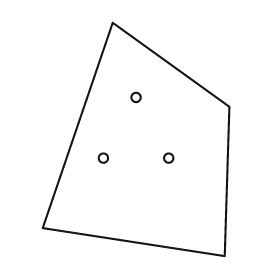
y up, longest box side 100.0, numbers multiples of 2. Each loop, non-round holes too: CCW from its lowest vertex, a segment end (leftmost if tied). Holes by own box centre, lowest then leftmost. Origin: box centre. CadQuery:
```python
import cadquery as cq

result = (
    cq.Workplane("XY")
    .moveTo(38.0, -50.0)
    .lineTo(40.0, 14.0)
    .lineTo(-10.0, 50.0)
    .lineTo(-40.0, -38.0)
    .close()
    .moveTo(-14.0, -8.0)
    .circle(2.0)
    .moveTo(14.0, -8.0)
    .circle(2.0)
    .moveTo(0.0, 18.0)
    .circle(2.0)
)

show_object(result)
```